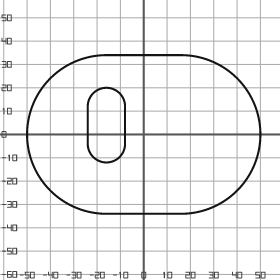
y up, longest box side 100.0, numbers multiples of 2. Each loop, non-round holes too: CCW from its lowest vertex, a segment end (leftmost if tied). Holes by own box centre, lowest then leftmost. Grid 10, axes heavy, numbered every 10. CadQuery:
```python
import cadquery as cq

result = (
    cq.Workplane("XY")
    .moveTo(-16.0, -34.0)
    .lineTo(16.0, -34.0)
    .threePointArc((50.0, 0.0), (16.0, 34.0))
    .lineTo(-16.0, 34.0)
    .threePointArc((-50.0, 0.0), (-16.0, -34.0))
    .close()
    .moveTo(-24.0, -4.0)
    .threePointArc((-16.0, -12.0), (-8.0, -4.0))
    .lineTo(-8.0, 12.0)
    .threePointArc((-16.0, 20.0), (-24.0, 12.0))
    .close()
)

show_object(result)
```